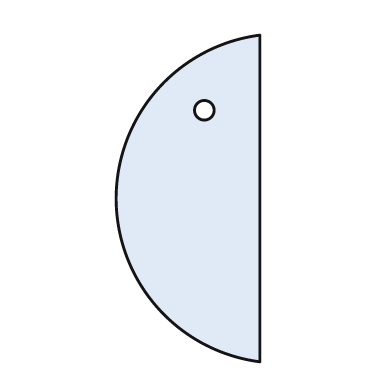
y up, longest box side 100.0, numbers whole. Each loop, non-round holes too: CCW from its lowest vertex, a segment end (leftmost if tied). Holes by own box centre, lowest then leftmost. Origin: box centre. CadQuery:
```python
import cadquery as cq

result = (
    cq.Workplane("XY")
    .moveTo(22.0, -50.0)
    .lineTo(22.0, 50.0)
    .threePointArc((-22.0, 0.0), (22.0, -50.0))
    .close()
    .moveTo(5.0, 27.0)
    .circle(3.0)
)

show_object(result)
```